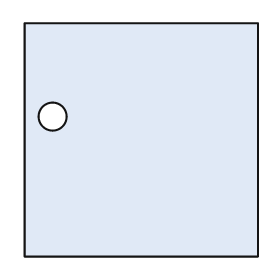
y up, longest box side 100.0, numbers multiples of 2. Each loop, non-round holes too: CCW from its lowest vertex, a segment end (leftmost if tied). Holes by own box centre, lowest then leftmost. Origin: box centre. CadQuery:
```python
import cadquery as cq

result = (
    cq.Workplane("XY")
    .moveTo(-50.0, -50.0)
    .lineTo(50.0, -50.0)
    .lineTo(50.0, 50.0)
    .lineTo(-50.0, 50.0)
    .close()
    .moveTo(-38.0, 10.0)
    .circle(6.0)
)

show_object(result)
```